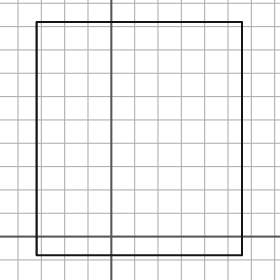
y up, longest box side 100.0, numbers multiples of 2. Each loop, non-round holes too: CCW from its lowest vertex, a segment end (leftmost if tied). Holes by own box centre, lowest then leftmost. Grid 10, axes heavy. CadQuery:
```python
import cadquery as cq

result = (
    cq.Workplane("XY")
    .moveTo(-32.0, -8.0)
    .lineTo(56.0, -8.0)
    .lineTo(56.0, 92.0)
    .lineTo(-32.0, 92.0)
    .close()
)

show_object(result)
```